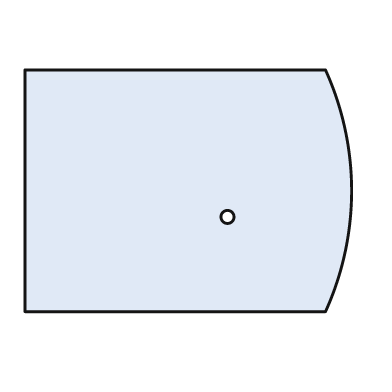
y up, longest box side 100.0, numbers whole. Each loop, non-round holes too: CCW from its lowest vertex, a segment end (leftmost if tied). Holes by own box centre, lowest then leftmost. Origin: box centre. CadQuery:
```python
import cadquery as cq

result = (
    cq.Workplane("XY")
    .moveTo(-50.0, -37.0)
    .lineTo(42.0, -37.0)
    .threePointArc((50.0, 0.0), (42.0, 37.0))
    .lineTo(-50.0, 37.0)
    .close()
    .moveTo(12.0, -8.0)
    .circle(2.0)
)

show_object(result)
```